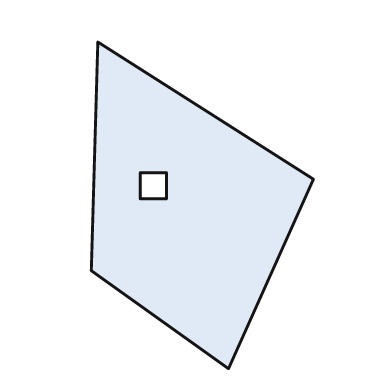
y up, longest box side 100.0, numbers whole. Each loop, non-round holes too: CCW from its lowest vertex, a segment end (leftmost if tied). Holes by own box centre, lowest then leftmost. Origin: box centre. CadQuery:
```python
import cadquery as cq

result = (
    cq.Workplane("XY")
    .moveTo(8.0, -50.0)
    .lineTo(34.0, 8.0)
    .lineTo(-32.0, 50.0)
    .lineTo(-34.0, -20.0)
    .close()
    .moveTo(-19.0, 2.0)
    .lineTo(-11.0, 2.0)
    .lineTo(-11.0, 10.0)
    .lineTo(-19.0, 10.0)
    .close()
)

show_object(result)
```